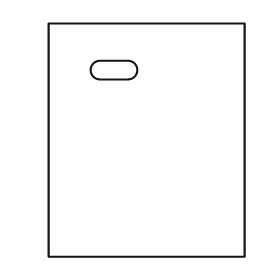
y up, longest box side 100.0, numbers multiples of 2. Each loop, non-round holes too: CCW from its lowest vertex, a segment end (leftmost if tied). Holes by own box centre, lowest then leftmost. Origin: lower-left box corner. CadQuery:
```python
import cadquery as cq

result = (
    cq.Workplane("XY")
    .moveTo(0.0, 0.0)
    .lineTo(84.0, 0.0)
    .lineTo(84.0, 100.0)
    .lineTo(0.0, 100.0)
    .close()
    .moveTo(22.0, 76.0)
    .lineTo(34.0, 76.0)
    .threePointArc((38.0, 80.0), (34.0, 84.0))
    .lineTo(22.0, 84.0)
    .threePointArc((18.0, 80.0), (22.0, 76.0))
    .close()
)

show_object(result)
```